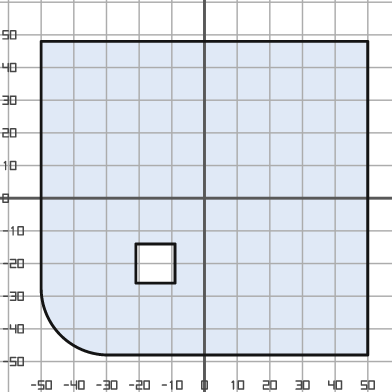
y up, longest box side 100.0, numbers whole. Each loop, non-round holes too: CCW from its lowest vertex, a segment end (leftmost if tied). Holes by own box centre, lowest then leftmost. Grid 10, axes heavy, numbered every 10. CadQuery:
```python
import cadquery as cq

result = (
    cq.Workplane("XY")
    .moveTo(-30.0, -48.0)
    .lineTo(50.0, -48.0)
    .lineTo(50.0, 48.0)
    .lineTo(-50.0, 48.0)
    .lineTo(-50.0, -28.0)
    .threePointArc((-44.0, -42.0), (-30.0, -48.0))
    .close()
    .moveTo(-21.0, -26.0)
    .lineTo(-9.0, -26.0)
    .lineTo(-9.0, -14.0)
    .lineTo(-21.0, -14.0)
    .close()
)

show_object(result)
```